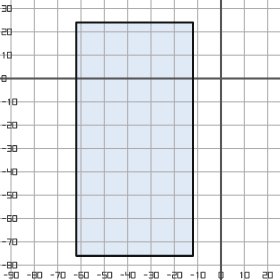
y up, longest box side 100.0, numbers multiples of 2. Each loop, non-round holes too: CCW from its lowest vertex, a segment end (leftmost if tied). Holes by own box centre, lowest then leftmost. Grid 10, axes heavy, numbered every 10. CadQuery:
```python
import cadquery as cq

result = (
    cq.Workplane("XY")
    .moveTo(-62.0, -76.0)
    .lineTo(-12.0, -76.0)
    .lineTo(-12.0, 24.0)
    .lineTo(-62.0, 24.0)
    .close()
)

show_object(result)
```